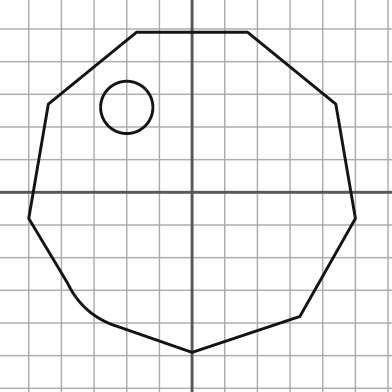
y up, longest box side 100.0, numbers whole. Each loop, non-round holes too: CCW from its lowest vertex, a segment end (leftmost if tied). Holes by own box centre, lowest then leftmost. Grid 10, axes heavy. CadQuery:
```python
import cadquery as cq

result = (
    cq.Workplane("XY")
    .moveTo(0.0, -49.0)
    .lineTo(33.0, -38.0)
    .lineTo(50.0, -8.0)
    .lineTo(44.0, 27.0)
    .lineTo(17.0, 49.0)
    .lineTo(-17.0, 49.0)
    .lineTo(-44.0, 27.0)
    .lineTo(-50.0, -8.0)
    .lineTo(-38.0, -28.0)
    .threePointArc((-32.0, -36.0), (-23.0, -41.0))
    .close()
    .moveTo(-20.0, 26.0)
    .circle(8.0)
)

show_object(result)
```